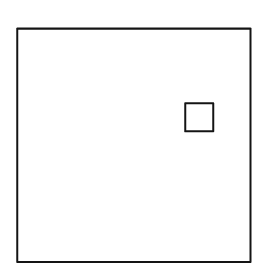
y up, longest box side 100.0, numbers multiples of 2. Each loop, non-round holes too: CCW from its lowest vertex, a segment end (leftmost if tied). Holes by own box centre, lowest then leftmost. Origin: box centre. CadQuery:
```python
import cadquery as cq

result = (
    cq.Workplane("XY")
    .moveTo(-50.0, -50.0)
    .lineTo(50.0, -50.0)
    .lineTo(50.0, 50.0)
    .lineTo(-50.0, 50.0)
    .close()
    .moveTo(22.0, 6.0)
    .lineTo(34.0, 6.0)
    .lineTo(34.0, 18.0)
    .lineTo(22.0, 18.0)
    .close()
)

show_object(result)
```